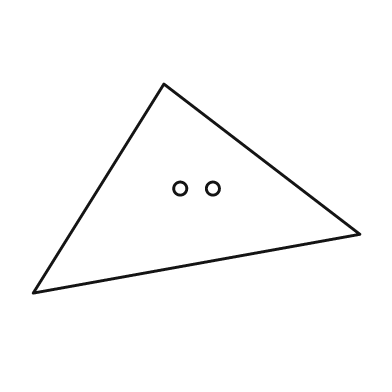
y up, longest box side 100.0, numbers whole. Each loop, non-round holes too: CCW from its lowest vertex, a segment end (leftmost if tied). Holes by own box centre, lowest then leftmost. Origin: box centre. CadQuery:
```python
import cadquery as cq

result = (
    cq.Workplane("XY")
    .moveTo(-50.0, -32.0)
    .lineTo(50.0, -14.0)
    .lineTo(-10.0, 32.0)
    .close()
    .moveTo(-5.0, 0.0)
    .circle(2.0)
    .moveTo(5.0, 0.0)
    .circle(2.0)
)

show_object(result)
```